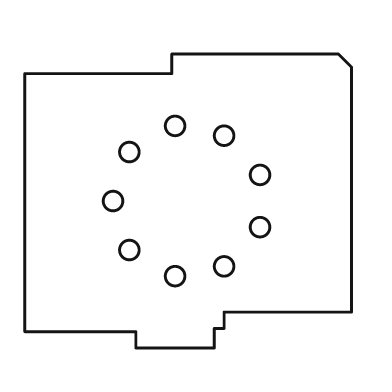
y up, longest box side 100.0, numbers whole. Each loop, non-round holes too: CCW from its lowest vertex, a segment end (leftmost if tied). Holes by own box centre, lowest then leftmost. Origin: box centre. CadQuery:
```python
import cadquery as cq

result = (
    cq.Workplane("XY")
    .moveTo(-16.0, -45.0)
    .lineTo(8.0, -45.0)
    .lineTo(8.0, -39.0)
    .lineTo(11.0, -39.0)
    .lineTo(11.0, -34.0)
    .lineTo(50.0, -34.0)
    .lineTo(50.0, 41.0)
    .lineTo(46.0, 45.0)
    .lineTo(-5.0, 45.0)
    .lineTo(-5.0, 39.0)
    .lineTo(-50.0, 39.0)
    .lineTo(-50.0, -40.0)
    .lineTo(-16.0, -40.0)
    .close()
    .moveTo(-4.0, -23.0)
    .circle(3.0)
    .moveTo(11.0, -20.0)
    .circle(3.0)
    .moveTo(-18.0, -15.0)
    .circle(3.0)
    .moveTo(22.0, -8.0)
    .circle(3.0)
    .moveTo(-23.0, 0.0)
    .circle(3.0)
    .moveTo(22.0, 8.0)
    .circle(3.0)
    .moveTo(-18.0, 15.0)
    .circle(3.0)
    .moveTo(11.0, 20.0)
    .circle(3.0)
    .moveTo(-4.0, 23.0)
    .circle(3.0)
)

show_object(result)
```